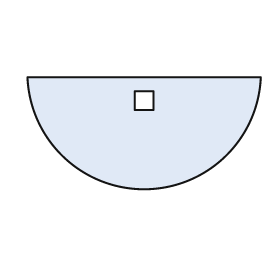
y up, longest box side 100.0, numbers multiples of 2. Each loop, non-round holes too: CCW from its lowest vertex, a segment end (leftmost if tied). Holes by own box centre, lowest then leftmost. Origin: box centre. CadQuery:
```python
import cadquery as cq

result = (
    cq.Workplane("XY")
    .moveTo(-50.0, 24.0)
    .threePointArc((0.0, -24.0), (50.0, 24.0))
    .close()
    .moveTo(-4.0, 10.0)
    .lineTo(4.0, 10.0)
    .lineTo(4.0, 18.0)
    .lineTo(-4.0, 18.0)
    .close()
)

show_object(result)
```